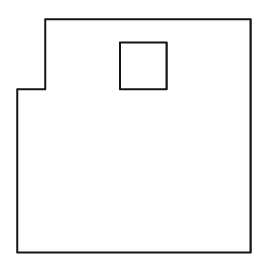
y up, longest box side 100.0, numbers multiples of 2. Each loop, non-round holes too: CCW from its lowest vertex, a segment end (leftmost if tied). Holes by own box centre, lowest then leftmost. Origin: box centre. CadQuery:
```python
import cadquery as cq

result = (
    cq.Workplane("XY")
    .moveTo(-50.0, -50.0)
    .lineTo(50.0, -50.0)
    .lineTo(50.0, 50.0)
    .lineTo(-38.0, 50.0)
    .lineTo(-38.0, 20.0)
    .lineTo(-50.0, 20.0)
    .close()
    .moveTo(-6.0, 20.0)
    .lineTo(14.0, 20.0)
    .lineTo(14.0, 40.0)
    .lineTo(-6.0, 40.0)
    .close()
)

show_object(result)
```